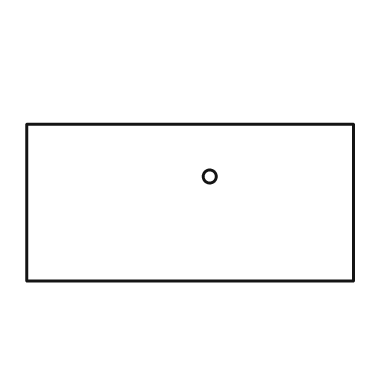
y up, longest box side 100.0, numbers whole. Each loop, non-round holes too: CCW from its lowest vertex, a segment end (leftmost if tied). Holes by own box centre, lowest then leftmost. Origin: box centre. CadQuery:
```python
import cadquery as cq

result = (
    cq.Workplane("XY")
    .moveTo(-50.0, -24.0)
    .lineTo(50.0, -24.0)
    .lineTo(50.0, 24.0)
    .lineTo(-50.0, 24.0)
    .close()
    .moveTo(6.0, 8.0)
    .circle(2.0)
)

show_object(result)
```